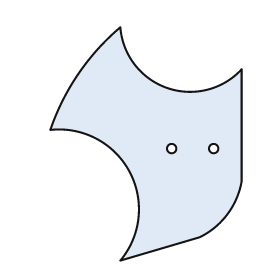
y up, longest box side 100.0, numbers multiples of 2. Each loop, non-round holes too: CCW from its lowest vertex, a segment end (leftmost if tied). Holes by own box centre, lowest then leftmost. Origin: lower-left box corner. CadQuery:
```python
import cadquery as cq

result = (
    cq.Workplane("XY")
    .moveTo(30.0, 0.0)
    .lineTo(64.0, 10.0)
    .threePointArc((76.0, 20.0), (82.0, 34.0))
    .lineTo(82.0, 82.0)
    .threePointArc((50.0, 74.0), (30.0, 100.0))
    .threePointArc((12.0, 80.0), (0.0, 56.0))
    .threePointArc((34.0, 38.0), (30.0, 0.0))
    .close()
    .moveTo(52.0, 48.0)
    .circle(2.0)
    .moveTo(70.0, 48.0)
    .circle(2.0)
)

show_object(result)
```